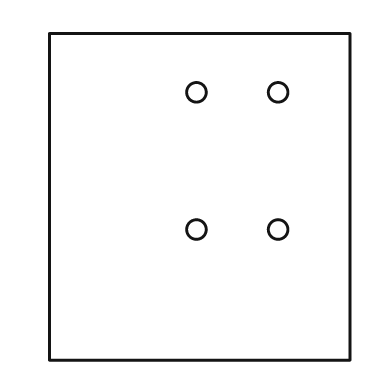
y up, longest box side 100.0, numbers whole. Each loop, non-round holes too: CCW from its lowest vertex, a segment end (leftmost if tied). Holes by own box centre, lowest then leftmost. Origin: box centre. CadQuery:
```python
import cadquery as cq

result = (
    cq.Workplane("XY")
    .moveTo(-46.0, -50.0)
    .lineTo(46.0, -50.0)
    .lineTo(46.0, 50.0)
    .lineTo(-46.0, 50.0)
    .close()
    .moveTo(-1.0, -10.0)
    .circle(3.0)
    .moveTo(24.0, -10.0)
    .circle(3.0)
    .moveTo(-1.0, 32.0)
    .circle(3.0)
    .moveTo(24.0, 32.0)
    .circle(3.0)
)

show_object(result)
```